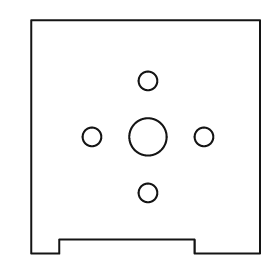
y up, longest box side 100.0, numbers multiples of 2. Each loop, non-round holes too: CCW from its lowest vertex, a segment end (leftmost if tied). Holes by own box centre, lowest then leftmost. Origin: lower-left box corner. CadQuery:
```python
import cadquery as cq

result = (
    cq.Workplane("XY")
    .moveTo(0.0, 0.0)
    .lineTo(12.0, 0.0)
    .lineTo(12.0, 6.0)
    .lineTo(70.0, 6.0)
    .lineTo(70.0, 0.0)
    .lineTo(98.0, 0.0)
    .lineTo(98.0, 100.0)
    .lineTo(0.0, 100.0)
    .close()
    .moveTo(50.0, 26.0)
    .circle(4.0)
    .moveTo(26.0, 50.0)
    .circle(4.0)
    .moveTo(50.0, 50.0)
    .circle(8.0)
    .moveTo(74.0, 50.0)
    .circle(4.0)
    .moveTo(50.0, 74.0)
    .circle(4.0)
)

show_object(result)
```